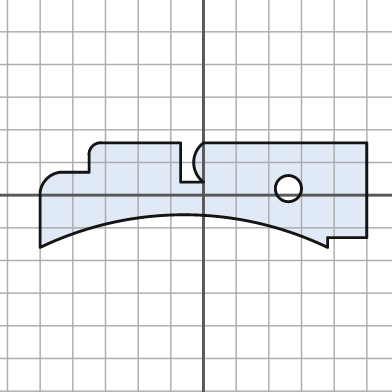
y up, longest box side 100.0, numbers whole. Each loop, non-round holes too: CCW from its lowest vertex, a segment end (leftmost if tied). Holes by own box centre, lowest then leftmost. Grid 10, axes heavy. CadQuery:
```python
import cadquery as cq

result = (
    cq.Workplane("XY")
    .moveTo(-50.0, -16.0)
    .threePointArc((-6.0, -6.0), (38.0, -16.0))
    .lineTo(38.0, -13.0)
    .lineTo(50.0, -13.0)
    .lineTo(50.0, 16.0)
    .lineTo(0.0, 16.0)
    .threePointArc((-3.0, 10.0), (0.0, 4.0))
    .lineTo(-7.0, 4.0)
    .lineTo(-7.0, 16.0)
    .lineTo(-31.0, 16.0)
    .threePointArc((-34.0, 15.0), (-35.0, 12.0))
    .lineTo(-35.0, 7.0)
    .lineTo(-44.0, 7.0)
    .threePointArc((-48.0, 5.0), (-50.0, 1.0))
    .close()
    .moveTo(26.0, 2.0)
    .circle(4.0)
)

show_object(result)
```